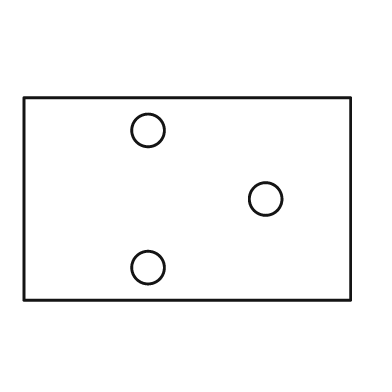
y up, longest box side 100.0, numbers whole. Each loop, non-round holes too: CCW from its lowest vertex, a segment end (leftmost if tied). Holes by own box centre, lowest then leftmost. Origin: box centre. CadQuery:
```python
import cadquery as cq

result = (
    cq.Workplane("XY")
    .moveTo(-50.0, -31.0)
    .lineTo(50.0, -31.0)
    .lineTo(50.0, 31.0)
    .lineTo(-50.0, 31.0)
    .close()
    .moveTo(-12.0, -21.0)
    .circle(5.0)
    .moveTo(24.0, 0.0)
    .circle(5.0)
    .moveTo(-12.0, 21.0)
    .circle(5.0)
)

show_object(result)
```